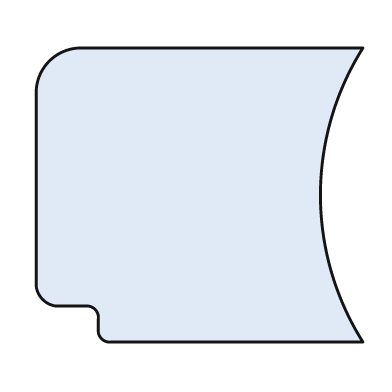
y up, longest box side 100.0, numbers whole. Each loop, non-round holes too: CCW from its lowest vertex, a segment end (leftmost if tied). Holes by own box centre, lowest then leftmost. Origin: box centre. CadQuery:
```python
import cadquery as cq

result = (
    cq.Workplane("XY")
    .moveTo(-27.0, -45.0)
    .lineTo(50.0, -45.0)
    .threePointArc((37.0, 0.0), (50.0, 45.0))
    .lineTo(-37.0, 45.0)
    .threePointArc((-46.0, 41.0), (-50.0, 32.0))
    .lineTo(-50.0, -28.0)
    .threePointArc((-48.0, -32.0), (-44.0, -34.0))
    .lineTo(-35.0, -34.0)
    .threePointArc((-32.0, -35.0), (-31.0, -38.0))
    .lineTo(-31.0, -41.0)
    .threePointArc((-30.0, -44.0), (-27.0, -45.0))
    .close()
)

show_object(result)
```